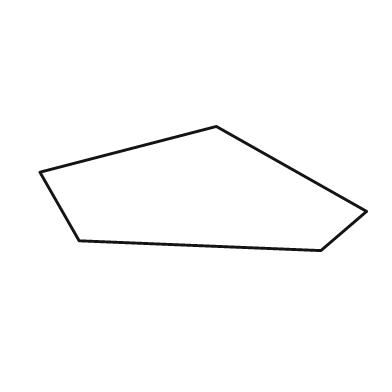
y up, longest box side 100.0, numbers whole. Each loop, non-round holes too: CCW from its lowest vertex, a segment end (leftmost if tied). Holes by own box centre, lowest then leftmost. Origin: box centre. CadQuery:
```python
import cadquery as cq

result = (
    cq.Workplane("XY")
    .moveTo(36.0, -19.0)
    .lineTo(50.0, -7.0)
    .lineTo(4.0, 19.0)
    .lineTo(-50.0, 5.0)
    .lineTo(-38.0, -16.0)
    .close()
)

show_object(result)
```